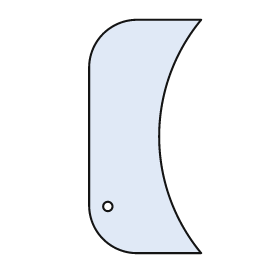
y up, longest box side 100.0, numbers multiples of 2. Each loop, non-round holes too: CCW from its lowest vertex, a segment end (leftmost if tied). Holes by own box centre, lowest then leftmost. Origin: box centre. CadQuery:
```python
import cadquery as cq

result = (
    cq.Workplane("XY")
    .moveTo(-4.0, -50.0)
    .lineTo(24.0, -50.0)
    .threePointArc((6.0, 0.0), (24.0, 50.0))
    .lineTo(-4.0, 50.0)
    .threePointArc((-18.0, 44.0), (-24.0, 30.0))
    .lineTo(-24.0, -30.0)
    .threePointArc((-18.0, -44.0), (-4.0, -50.0))
    .close()
    .moveTo(-16.0, -30.0)
    .circle(2.0)
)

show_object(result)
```